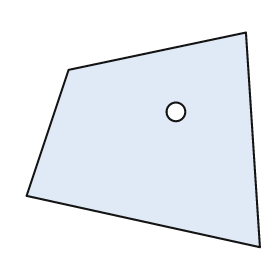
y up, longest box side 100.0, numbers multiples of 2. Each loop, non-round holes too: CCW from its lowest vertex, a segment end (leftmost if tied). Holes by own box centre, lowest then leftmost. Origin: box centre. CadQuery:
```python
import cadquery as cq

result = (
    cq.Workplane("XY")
    .moveTo(50.0, -46.0)
    .lineTo(44.0, 46.0)
    .lineTo(-32.0, 30.0)
    .lineTo(-50.0, -24.0)
    .close()
    .moveTo(14.0, 12.0)
    .circle(4.0)
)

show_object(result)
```